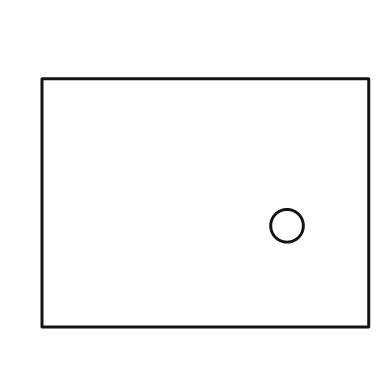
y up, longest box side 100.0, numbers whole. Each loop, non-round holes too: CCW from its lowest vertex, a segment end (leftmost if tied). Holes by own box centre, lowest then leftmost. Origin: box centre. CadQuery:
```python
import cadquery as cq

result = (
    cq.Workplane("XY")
    .moveTo(-50.0, -38.0)
    .lineTo(50.0, -38.0)
    .lineTo(50.0, 38.0)
    .lineTo(-50.0, 38.0)
    .close()
    .moveTo(25.0, -7.0)
    .circle(5.0)
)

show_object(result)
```